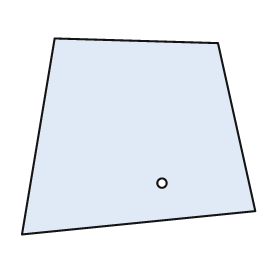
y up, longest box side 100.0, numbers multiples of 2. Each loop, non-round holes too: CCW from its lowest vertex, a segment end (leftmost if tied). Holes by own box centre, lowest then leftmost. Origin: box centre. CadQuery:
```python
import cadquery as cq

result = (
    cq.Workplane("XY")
    .moveTo(-50.0, -42.0)
    .lineTo(50.0, -32.0)
    .lineTo(34.0, 40.0)
    .lineTo(-36.0, 42.0)
    .close()
    .moveTo(10.0, -20.0)
    .circle(2.0)
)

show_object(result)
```